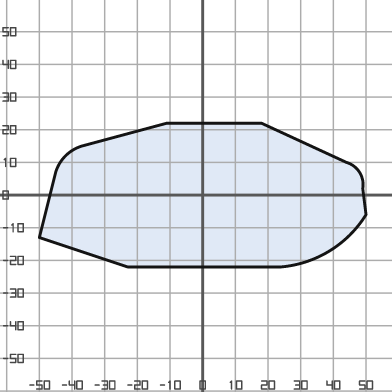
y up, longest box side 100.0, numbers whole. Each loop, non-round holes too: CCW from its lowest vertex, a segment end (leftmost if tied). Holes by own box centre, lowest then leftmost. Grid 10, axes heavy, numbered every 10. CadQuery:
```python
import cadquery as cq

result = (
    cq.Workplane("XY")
    .moveTo(-23.0, -22.0)
    .lineTo(24.0, -22.0)
    .threePointArc((39.0, -17.0), (50.0, -6.0))
    .lineTo(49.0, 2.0)
    .threePointArc((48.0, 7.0), (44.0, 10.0))
    .lineTo(18.0, 22.0)
    .lineTo(-11.0, 22.0)
    .lineTo(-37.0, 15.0)
    .threePointArc((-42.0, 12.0), (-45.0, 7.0))
    .lineTo(-50.0, -13.0)
    .close()
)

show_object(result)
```